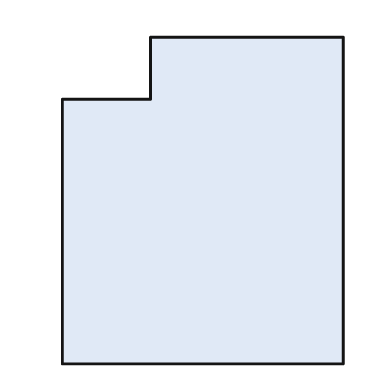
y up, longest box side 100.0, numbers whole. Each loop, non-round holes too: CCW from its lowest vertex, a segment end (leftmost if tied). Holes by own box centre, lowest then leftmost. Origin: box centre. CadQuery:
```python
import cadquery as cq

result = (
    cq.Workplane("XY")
    .moveTo(-43.0, -50.0)
    .lineTo(43.0, -50.0)
    .lineTo(43.0, 50.0)
    .lineTo(-16.0, 50.0)
    .lineTo(-16.0, 31.0)
    .lineTo(-43.0, 31.0)
    .close()
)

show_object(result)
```